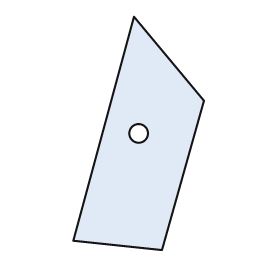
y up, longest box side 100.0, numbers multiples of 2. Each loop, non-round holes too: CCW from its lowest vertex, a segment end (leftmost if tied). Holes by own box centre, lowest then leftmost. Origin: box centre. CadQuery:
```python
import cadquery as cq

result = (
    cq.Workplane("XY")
    .moveTo(10.0, -50.0)
    .lineTo(28.0, 14.0)
    .lineTo(-2.0, 50.0)
    .lineTo(-28.0, -46.0)
    .close()
    .moveTo(0.0, 0.0)
    .circle(4.0)
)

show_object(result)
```